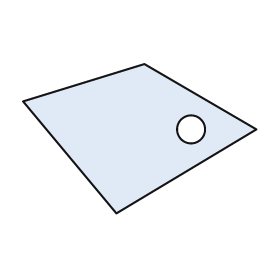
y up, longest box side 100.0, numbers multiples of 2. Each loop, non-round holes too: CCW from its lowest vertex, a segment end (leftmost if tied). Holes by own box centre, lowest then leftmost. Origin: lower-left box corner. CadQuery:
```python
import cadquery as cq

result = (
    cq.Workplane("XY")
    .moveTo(40.0, 0.0)
    .lineTo(100.0, 36.0)
    .lineTo(52.0, 64.0)
    .lineTo(0.0, 48.0)
    .close()
    .moveTo(72.0, 36.0)
    .circle(6.0)
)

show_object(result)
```